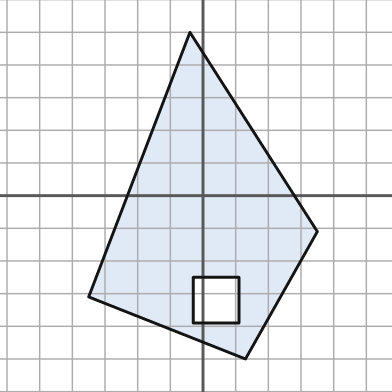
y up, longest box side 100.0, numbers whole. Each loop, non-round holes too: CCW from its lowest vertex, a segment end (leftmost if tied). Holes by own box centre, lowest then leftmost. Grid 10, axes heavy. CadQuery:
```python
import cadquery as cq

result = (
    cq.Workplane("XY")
    .moveTo(13.0, -50.0)
    .lineTo(35.0, -11.0)
    .lineTo(-4.0, 50.0)
    .lineTo(-35.0, -31.0)
    .close()
    .moveTo(-3.0, -39.0)
    .lineTo(11.0, -39.0)
    .lineTo(11.0, -25.0)
    .lineTo(-3.0, -25.0)
    .close()
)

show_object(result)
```